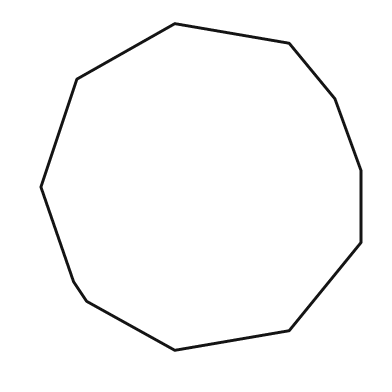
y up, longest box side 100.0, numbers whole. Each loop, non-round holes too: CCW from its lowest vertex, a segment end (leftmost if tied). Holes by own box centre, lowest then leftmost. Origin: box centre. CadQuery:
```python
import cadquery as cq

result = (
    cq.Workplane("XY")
    .moveTo(-8.0, -50.0)
    .lineTo(27.0, -44.0)
    .lineTo(49.0, -17.0)
    .lineTo(49.0, 5.0)
    .lineTo(41.0, 27.0)
    .lineTo(27.0, 44.0)
    .lineTo(-8.0, 50.0)
    .lineTo(-38.0, 33.0)
    .lineTo(-49.0, 0.0)
    .lineTo(-39.0, -29.0)
    .lineTo(-35.0, -35.0)
    .close()
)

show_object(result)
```